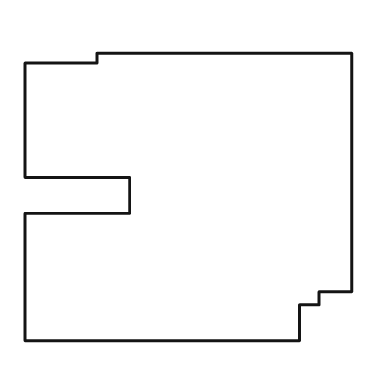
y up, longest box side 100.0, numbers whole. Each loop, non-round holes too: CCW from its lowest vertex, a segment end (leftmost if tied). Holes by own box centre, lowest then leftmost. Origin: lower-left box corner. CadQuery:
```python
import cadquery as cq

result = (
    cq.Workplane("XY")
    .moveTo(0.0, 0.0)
    .lineTo(84.0, 0.0)
    .lineTo(84.0, 11.0)
    .lineTo(90.0, 11.0)
    .lineTo(90.0, 15.0)
    .lineTo(100.0, 15.0)
    .lineTo(100.0, 88.0)
    .lineTo(22.0, 88.0)
    .lineTo(22.0, 85.0)
    .lineTo(0.0, 85.0)
    .lineTo(0.0, 50.0)
    .lineTo(32.0, 50.0)
    .lineTo(32.0, 39.0)
    .lineTo(0.0, 39.0)
    .close()
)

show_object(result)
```